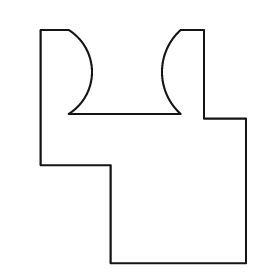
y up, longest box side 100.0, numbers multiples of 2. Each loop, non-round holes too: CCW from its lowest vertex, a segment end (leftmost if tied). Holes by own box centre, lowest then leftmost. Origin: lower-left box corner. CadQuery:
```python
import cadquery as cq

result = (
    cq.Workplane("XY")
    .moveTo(30.0, 0.0)
    .lineTo(88.0, 0.0)
    .lineTo(88.0, 62.0)
    .lineTo(70.0, 62.0)
    .lineTo(70.0, 100.0)
    .lineTo(60.0, 100.0)
    .threePointArc((52.0, 82.0), (60.0, 64.0))
    .lineTo(12.0, 64.0)
    .threePointArc((22.0, 82.0), (12.0, 100.0))
    .lineTo(0.0, 100.0)
    .lineTo(0.0, 42.0)
    .lineTo(30.0, 42.0)
    .close()
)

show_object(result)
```